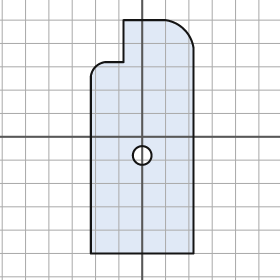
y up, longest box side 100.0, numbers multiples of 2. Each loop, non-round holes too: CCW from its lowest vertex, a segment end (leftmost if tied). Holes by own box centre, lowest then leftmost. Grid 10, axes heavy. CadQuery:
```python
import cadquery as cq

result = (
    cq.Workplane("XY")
    .moveTo(-22.0, -50.0)
    .lineTo(22.0, -50.0)
    .lineTo(22.0, 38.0)
    .threePointArc((18.0, 46.0), (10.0, 50.0))
    .lineTo(-8.0, 50.0)
    .lineTo(-8.0, 32.0)
    .lineTo(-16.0, 32.0)
    .threePointArc((-20.0, 30.0), (-22.0, 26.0))
    .close()
    .moveTo(0.0, -8.0)
    .circle(4.0)
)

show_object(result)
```